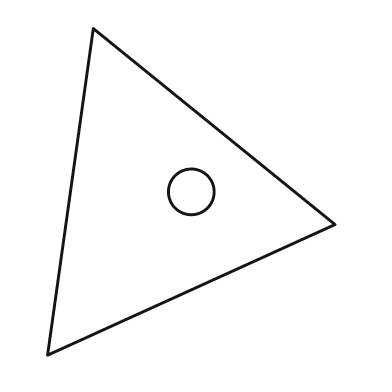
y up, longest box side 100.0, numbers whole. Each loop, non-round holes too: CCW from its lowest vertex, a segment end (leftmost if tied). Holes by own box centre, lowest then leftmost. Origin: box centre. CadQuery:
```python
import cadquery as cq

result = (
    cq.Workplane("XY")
    .moveTo(-44.0, -50.0)
    .lineTo(44.0, -10.0)
    .lineTo(-30.0, 50.0)
    .close()
    .moveTo(0.0, 0.0)
    .circle(7.0)
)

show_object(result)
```